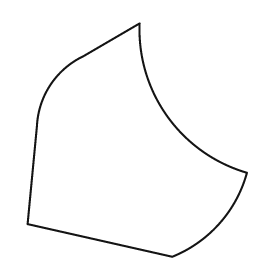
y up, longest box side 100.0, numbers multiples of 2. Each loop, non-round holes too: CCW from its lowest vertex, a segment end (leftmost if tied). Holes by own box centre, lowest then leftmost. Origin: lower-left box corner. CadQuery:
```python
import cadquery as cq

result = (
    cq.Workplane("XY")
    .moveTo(62.0, 0.0)
    .threePointArc((82.0, 14.0), (94.0, 36.0))
    .threePointArc((60.0, 60.0), (48.0, 100.0))
    .lineTo(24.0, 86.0)
    .threePointArc((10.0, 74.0), (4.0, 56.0))
    .lineTo(0.0, 14.0)
    .close()
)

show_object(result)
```